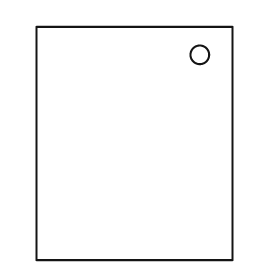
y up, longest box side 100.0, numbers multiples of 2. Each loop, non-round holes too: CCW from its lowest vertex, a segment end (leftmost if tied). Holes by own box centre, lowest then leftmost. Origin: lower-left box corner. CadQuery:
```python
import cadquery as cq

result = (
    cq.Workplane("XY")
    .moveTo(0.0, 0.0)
    .lineTo(84.0, 0.0)
    .lineTo(84.0, 100.0)
    .lineTo(0.0, 100.0)
    .close()
    .moveTo(70.0, 88.0)
    .circle(4.0)
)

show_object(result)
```